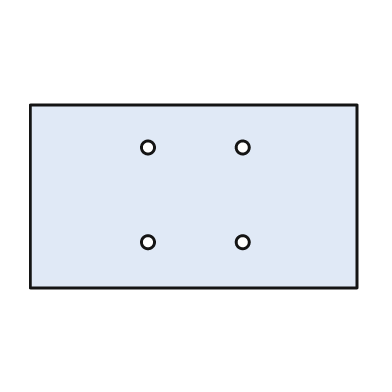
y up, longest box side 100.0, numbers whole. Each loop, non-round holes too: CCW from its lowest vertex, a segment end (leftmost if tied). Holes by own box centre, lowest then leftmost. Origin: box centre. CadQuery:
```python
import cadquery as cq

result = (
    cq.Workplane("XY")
    .moveTo(-50.0, -28.0)
    .lineTo(50.0, -28.0)
    .lineTo(50.0, 28.0)
    .lineTo(-50.0, 28.0)
    .close()
    .moveTo(-14.0, -14.0)
    .circle(2.0)
    .moveTo(15.0, -14.0)
    .circle(2.0)
    .moveTo(-14.0, 15.0)
    .circle(2.0)
    .moveTo(15.0, 15.0)
    .circle(2.0)
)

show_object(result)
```